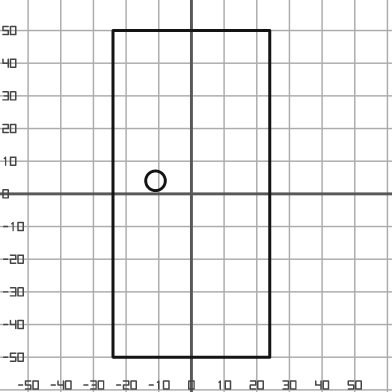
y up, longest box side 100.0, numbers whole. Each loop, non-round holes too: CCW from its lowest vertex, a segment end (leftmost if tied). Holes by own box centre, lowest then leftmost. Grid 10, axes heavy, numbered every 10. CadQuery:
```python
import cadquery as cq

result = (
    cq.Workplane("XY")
    .moveTo(-24.0, -50.0)
    .lineTo(24.0, -50.0)
    .lineTo(24.0, 50.0)
    .lineTo(-24.0, 50.0)
    .close()
    .moveTo(-11.0, 4.0)
    .circle(3.0)
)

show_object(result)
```